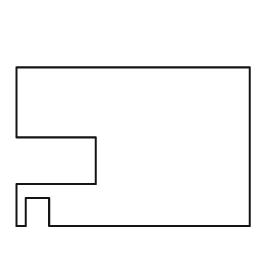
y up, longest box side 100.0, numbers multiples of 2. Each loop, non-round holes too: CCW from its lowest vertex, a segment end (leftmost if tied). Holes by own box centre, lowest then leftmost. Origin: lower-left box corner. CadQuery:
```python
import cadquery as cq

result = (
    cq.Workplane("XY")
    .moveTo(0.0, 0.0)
    .lineTo(4.0, 0.0)
    .lineTo(4.0, 12.0)
    .lineTo(14.0, 12.0)
    .lineTo(14.0, 0.0)
    .lineTo(100.0, 0.0)
    .lineTo(100.0, 68.0)
    .lineTo(0.0, 68.0)
    .lineTo(0.0, 38.0)
    .lineTo(34.0, 38.0)
    .lineTo(34.0, 18.0)
    .lineTo(0.0, 18.0)
    .close()
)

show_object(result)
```